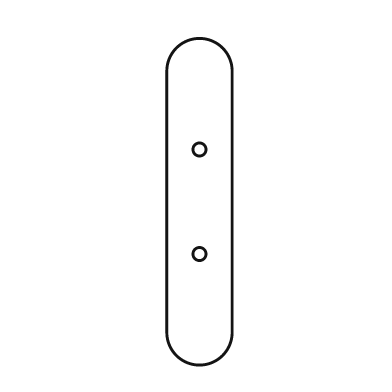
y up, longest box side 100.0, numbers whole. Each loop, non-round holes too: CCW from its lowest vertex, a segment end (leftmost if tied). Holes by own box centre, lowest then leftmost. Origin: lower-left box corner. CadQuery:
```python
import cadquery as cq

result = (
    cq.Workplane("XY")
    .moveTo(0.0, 10.0)
    .threePointArc((10.0, 0.0), (20.0, 10.0))
    .lineTo(20.0, 90.0)
    .threePointArc((10.0, 100.0), (0.0, 90.0))
    .close()
    .moveTo(10.0, 34.0)
    .circle(2.0)
    .moveTo(10.0, 66.0)
    .circle(2.0)
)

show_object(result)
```